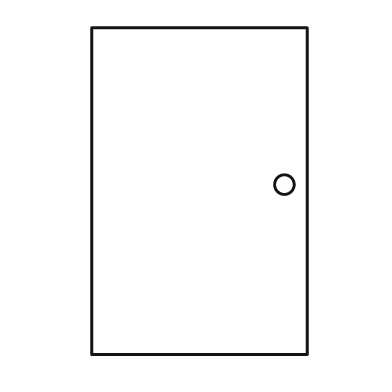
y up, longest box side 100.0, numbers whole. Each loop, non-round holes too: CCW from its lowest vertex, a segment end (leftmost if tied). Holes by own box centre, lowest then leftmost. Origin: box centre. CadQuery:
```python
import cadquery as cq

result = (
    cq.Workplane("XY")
    .moveTo(-33.0, -50.0)
    .lineTo(33.0, -50.0)
    .lineTo(33.0, 50.0)
    .lineTo(-33.0, 50.0)
    .close()
    .moveTo(26.0, 2.0)
    .circle(3.0)
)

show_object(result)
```